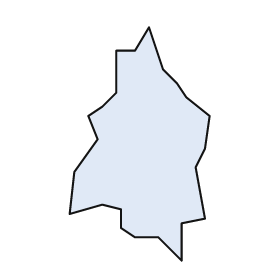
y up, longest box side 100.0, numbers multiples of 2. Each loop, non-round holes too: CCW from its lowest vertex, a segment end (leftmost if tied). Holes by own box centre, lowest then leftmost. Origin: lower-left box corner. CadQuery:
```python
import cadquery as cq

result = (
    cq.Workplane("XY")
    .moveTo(48.0, 0.0)
    .lineTo(48.0, 16.0)
    .lineTo(58.0, 18.0)
    .lineTo(54.0, 40.0)
    .lineTo(58.0, 48.0)
    .lineTo(60.0, 62.0)
    .lineTo(50.0, 70.0)
    .lineTo(46.0, 76.0)
    .lineTo(40.0, 82.0)
    .lineTo(34.0, 100.0)
    .lineTo(28.0, 90.0)
    .lineTo(20.0, 90.0)
    .lineTo(20.0, 72.0)
    .lineTo(14.0, 66.0)
    .lineTo(8.0, 62.0)
    .lineTo(12.0, 52.0)
    .lineTo(2.0, 38.0)
    .lineTo(0.0, 20.0)
    .lineTo(14.0, 24.0)
    .lineTo(22.0, 22.0)
    .lineTo(22.0, 14.0)
    .lineTo(28.0, 10.0)
    .lineTo(38.0, 10.0)
    .close()
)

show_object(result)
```